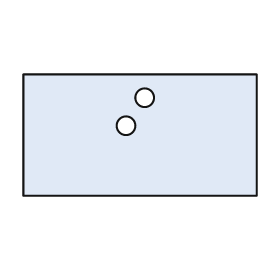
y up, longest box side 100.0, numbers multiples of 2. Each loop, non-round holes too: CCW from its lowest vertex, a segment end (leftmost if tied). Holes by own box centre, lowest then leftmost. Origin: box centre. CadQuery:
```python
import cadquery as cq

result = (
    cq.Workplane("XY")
    .moveTo(-50.0, -26.0)
    .lineTo(50.0, -26.0)
    .lineTo(50.0, 26.0)
    .lineTo(-50.0, 26.0)
    .close()
    .moveTo(-6.0, 4.0)
    .circle(4.0)
    .moveTo(2.0, 16.0)
    .circle(4.0)
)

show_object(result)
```